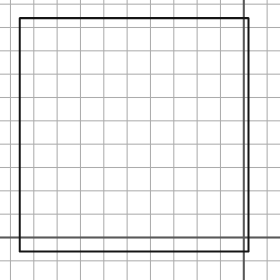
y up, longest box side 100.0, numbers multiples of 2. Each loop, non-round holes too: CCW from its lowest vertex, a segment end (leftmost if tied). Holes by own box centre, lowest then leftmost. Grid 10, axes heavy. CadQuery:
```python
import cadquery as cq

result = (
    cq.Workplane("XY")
    .moveTo(-96.0, -6.0)
    .lineTo(2.0, -6.0)
    .lineTo(2.0, 94.0)
    .lineTo(-96.0, 94.0)
    .close()
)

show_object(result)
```